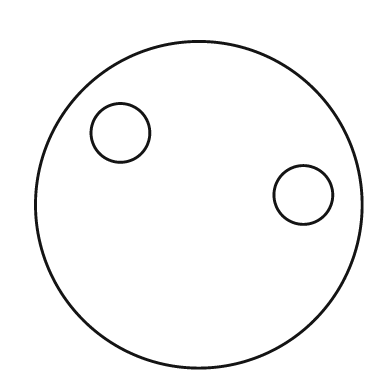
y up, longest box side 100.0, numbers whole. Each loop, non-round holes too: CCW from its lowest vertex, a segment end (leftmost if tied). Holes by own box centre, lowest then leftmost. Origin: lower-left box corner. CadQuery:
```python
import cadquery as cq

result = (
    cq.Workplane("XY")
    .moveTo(50.0, 50.0)
    .circle(50.0)
    .moveTo(82.0, 53.0)
    .circle(9.0)
    .moveTo(26.0, 72.0)
    .circle(9.0)
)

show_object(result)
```